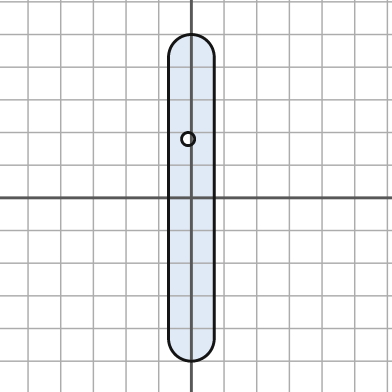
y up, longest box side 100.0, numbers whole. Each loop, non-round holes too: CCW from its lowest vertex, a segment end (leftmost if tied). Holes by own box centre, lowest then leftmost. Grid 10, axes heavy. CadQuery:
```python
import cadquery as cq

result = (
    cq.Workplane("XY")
    .moveTo(-7.0, -43.0)
    .threePointArc((0.0, -50.0), (7.0, -43.0))
    .lineTo(7.0, 43.0)
    .threePointArc((0.0, 50.0), (-7.0, 43.0))
    .close()
    .moveTo(-1.0, 18.0)
    .circle(2.0)
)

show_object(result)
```